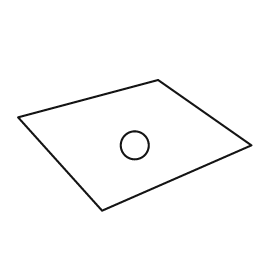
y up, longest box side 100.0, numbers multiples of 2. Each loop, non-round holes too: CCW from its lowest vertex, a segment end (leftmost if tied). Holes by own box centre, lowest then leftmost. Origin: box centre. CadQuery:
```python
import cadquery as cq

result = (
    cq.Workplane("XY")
    .moveTo(-14.0, -28.0)
    .lineTo(50.0, 0.0)
    .lineTo(10.0, 28.0)
    .lineTo(-50.0, 12.0)
    .close()
    .moveTo(0.0, 0.0)
    .circle(6.0)
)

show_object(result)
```